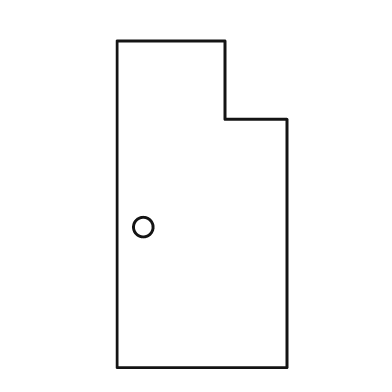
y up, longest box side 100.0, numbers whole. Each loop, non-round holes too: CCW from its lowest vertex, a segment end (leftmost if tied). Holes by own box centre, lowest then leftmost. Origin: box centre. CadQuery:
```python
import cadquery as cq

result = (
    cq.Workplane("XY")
    .moveTo(-26.0, -50.0)
    .lineTo(26.0, -50.0)
    .lineTo(26.0, 26.0)
    .lineTo(7.0, 26.0)
    .lineTo(7.0, 50.0)
    .lineTo(-26.0, 50.0)
    .close()
    .moveTo(-18.0, -7.0)
    .circle(3.0)
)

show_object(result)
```